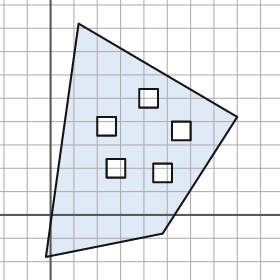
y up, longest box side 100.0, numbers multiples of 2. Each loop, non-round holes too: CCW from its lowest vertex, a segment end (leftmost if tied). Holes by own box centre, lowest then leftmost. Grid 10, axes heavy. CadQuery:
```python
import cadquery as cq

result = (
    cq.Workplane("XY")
    .moveTo(-2.0, -18.0)
    .lineTo(48.0, -8.0)
    .lineTo(80.0, 42.0)
    .lineTo(12.0, 82.0)
    .close()
    .moveTo(44.0, 14.0)
    .lineTo(52.0, 14.0)
    .lineTo(52.0, 22.0)
    .lineTo(44.0, 22.0)
    .close()
    .moveTo(24.0, 16.0)
    .lineTo(32.0, 16.0)
    .lineTo(32.0, 24.0)
    .lineTo(24.0, 24.0)
    .close()
    .moveTo(52.0, 32.0)
    .lineTo(60.0, 32.0)
    .lineTo(60.0, 40.0)
    .lineTo(52.0, 40.0)
    .close()
    .moveTo(20.0, 34.0)
    .lineTo(28.0, 34.0)
    .lineTo(28.0, 42.0)
    .lineTo(20.0, 42.0)
    .close()
    .moveTo(38.0, 46.0)
    .lineTo(46.0, 46.0)
    .lineTo(46.0, 54.0)
    .lineTo(38.0, 54.0)
    .close()
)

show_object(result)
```